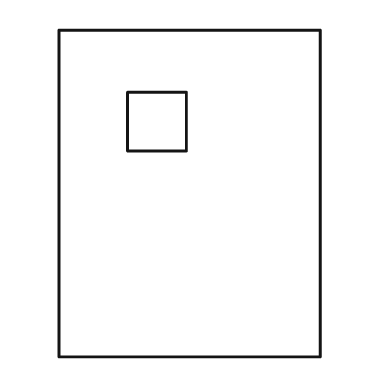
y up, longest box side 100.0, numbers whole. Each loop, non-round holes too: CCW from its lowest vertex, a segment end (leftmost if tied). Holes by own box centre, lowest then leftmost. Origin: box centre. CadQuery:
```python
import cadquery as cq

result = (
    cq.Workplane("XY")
    .moveTo(-40.0, -50.0)
    .lineTo(40.0, -50.0)
    .lineTo(40.0, 50.0)
    .lineTo(-40.0, 50.0)
    .close()
    .moveTo(-19.0, 13.0)
    .lineTo(-1.0, 13.0)
    .lineTo(-1.0, 31.0)
    .lineTo(-19.0, 31.0)
    .close()
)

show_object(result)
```